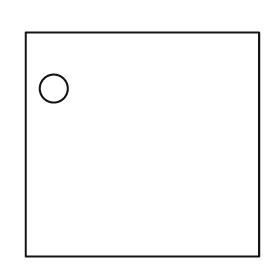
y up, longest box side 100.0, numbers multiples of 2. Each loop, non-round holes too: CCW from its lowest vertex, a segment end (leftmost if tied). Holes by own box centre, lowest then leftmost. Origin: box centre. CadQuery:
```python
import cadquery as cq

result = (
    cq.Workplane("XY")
    .moveTo(-50.0, -48.0)
    .lineTo(50.0, -48.0)
    .lineTo(50.0, 48.0)
    .lineTo(-50.0, 48.0)
    .close()
    .moveTo(-38.0, 24.0)
    .circle(6.0)
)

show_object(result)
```